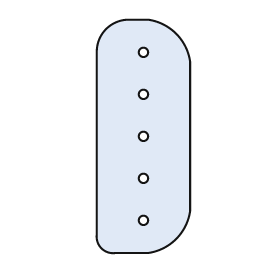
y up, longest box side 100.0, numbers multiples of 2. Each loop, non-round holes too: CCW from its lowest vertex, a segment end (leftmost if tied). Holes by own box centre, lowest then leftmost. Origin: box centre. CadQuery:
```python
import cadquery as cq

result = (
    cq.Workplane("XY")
    .moveTo(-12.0, -50.0)
    .lineTo(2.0, -50.0)
    .threePointArc((14.0, -44.0), (20.0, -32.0))
    .lineTo(20.0, 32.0)
    .threePointArc((14.0, 44.0), (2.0, 50.0))
    .lineTo(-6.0, 50.0)
    .threePointArc((-16.0, 46.0), (-20.0, 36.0))
    .lineTo(-20.0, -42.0)
    .threePointArc((-18.0, -48.0), (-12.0, -50.0))
    .close()
    .moveTo(0.0, -36.0)
    .circle(2.0)
    .moveTo(0.0, -18.0)
    .circle(2.0)
    .moveTo(0.0, 0.0)
    .circle(2.0)
    .moveTo(0.0, 18.0)
    .circle(2.0)
    .moveTo(0.0, 36.0)
    .circle(2.0)
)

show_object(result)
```